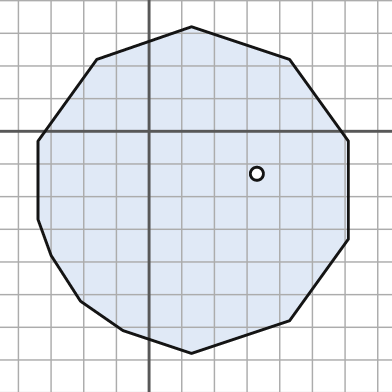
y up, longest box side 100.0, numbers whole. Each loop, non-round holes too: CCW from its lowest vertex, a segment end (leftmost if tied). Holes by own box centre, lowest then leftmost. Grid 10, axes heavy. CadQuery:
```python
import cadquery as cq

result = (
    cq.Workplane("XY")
    .moveTo(13.0, -68.0)
    .lineTo(43.0, -58.0)
    .lineTo(61.0, -33.0)
    .lineTo(61.0, -3.0)
    .lineTo(43.0, 22.0)
    .lineTo(13.0, 32.0)
    .lineTo(-16.0, 22.0)
    .lineTo(-34.0, -3.0)
    .lineTo(-34.0, -27.0)
    .lineTo(-30.0, -38.0)
    .lineTo(-21.0, -52.0)
    .lineTo(-8.0, -61.0)
    .close()
    .moveTo(33.0, -13.0)
    .circle(2.0)
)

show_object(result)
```